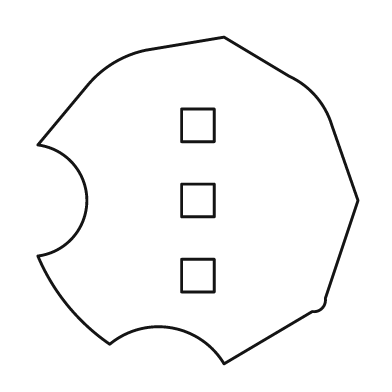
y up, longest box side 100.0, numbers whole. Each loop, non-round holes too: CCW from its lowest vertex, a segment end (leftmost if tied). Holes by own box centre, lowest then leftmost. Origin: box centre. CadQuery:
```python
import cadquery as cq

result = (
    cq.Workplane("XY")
    .moveTo(8.0, -50.0)
    .lineTo(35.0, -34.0)
    .threePointArc((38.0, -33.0), (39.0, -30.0))
    .lineTo(49.0, 0.0)
    .lineTo(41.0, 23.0)
    .threePointArc((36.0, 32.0), (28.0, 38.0))
    .lineTo(8.0, 50.0)
    .lineTo(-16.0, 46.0)
    .threePointArc((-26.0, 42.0), (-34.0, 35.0))
    .lineTo(-49.0, 17.0)
    .threePointArc((-34.0, 0.0), (-49.0, -17.0))
    .threePointArc((-40.0, -32.0), (-27.0, -44.0))
    .threePointArc((-8.0, -39.0), (8.0, -50.0))
    .close()
    .moveTo(-5.0, -28.0)
    .lineTo(5.0, -28.0)
    .lineTo(5.0, -18.0)
    .lineTo(-5.0, -18.0)
    .close()
    .moveTo(-5.0, -5.0)
    .lineTo(5.0, -5.0)
    .lineTo(5.0, 5.0)
    .lineTo(-5.0, 5.0)
    .close()
    .moveTo(-5.0, 18.0)
    .lineTo(5.0, 18.0)
    .lineTo(5.0, 28.0)
    .lineTo(-5.0, 28.0)
    .close()
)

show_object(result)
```